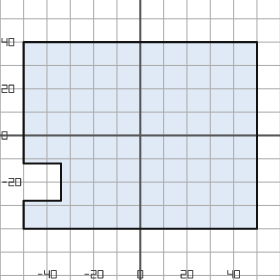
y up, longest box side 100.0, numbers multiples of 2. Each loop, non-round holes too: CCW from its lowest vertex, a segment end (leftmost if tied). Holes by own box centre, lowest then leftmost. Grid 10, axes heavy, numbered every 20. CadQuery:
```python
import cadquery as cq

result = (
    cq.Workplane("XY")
    .moveTo(-50.0, -40.0)
    .lineTo(50.0, -40.0)
    .lineTo(50.0, 40.0)
    .lineTo(-50.0, 40.0)
    .lineTo(-50.0, -12.0)
    .lineTo(-34.0, -12.0)
    .lineTo(-34.0, -28.0)
    .lineTo(-50.0, -28.0)
    .close()
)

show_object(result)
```